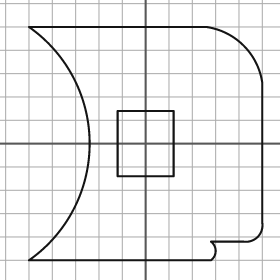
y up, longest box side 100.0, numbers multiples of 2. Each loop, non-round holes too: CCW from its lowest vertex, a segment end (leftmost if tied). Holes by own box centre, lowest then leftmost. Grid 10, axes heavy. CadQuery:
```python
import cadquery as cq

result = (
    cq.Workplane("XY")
    .moveTo(-50.0, -50.0)
    .lineTo(28.0, -50.0)
    .threePointArc((30.0, -46.0), (28.0, -42.0))
    .lineTo(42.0, -42.0)
    .threePointArc((48.0, -40.0), (50.0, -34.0))
    .lineTo(50.0, 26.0)
    .threePointArc((42.0, 42.0), (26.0, 50.0))
    .lineTo(-50.0, 50.0)
    .threePointArc((-24.0, 0.0), (-50.0, -50.0))
    .close()
    .moveTo(-12.0, -14.0)
    .lineTo(12.0, -14.0)
    .lineTo(12.0, 14.0)
    .lineTo(-12.0, 14.0)
    .close()
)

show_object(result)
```